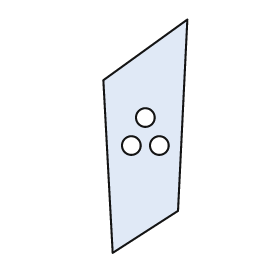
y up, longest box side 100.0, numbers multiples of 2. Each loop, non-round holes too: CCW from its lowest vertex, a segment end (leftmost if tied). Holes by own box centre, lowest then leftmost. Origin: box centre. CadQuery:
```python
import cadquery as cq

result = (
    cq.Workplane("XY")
    .moveTo(-14.0, -50.0)
    .lineTo(14.0, -32.0)
    .lineTo(18.0, 50.0)
    .lineTo(-18.0, 24.0)
    .close()
    .moveTo(-6.0, -4.0)
    .circle(4.0)
    .moveTo(6.0, -4.0)
    .circle(4.0)
    .moveTo(0.0, 8.0)
    .circle(4.0)
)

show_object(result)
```